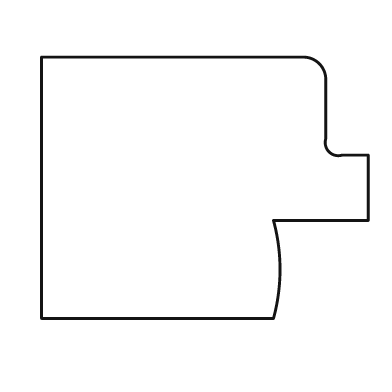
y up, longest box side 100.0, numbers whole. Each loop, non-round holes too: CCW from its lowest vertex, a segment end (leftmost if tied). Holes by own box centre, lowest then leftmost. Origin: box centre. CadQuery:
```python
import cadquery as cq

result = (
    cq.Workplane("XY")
    .moveTo(-50.0, -40.0)
    .lineTo(21.0, -40.0)
    .threePointArc((23.0, -25.0), (21.0, -10.0))
    .lineTo(50.0, -10.0)
    .lineTo(50.0, 10.0)
    .lineTo(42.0, 10.0)
    .threePointArc((38.0, 11.0), (37.0, 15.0))
    .lineTo(37.0, 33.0)
    .threePointArc((35.0, 38.0), (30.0, 40.0))
    .lineTo(-50.0, 40.0)
    .close()
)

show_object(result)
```